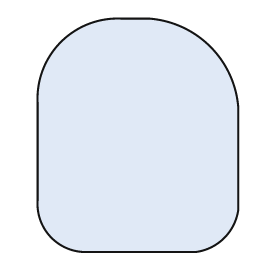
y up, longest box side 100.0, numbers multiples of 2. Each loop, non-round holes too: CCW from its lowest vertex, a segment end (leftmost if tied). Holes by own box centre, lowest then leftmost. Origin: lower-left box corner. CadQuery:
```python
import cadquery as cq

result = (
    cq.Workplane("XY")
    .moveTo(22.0, 0.0)
    .lineTo(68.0, 0.0)
    .threePointArc((80.0, 6.0), (86.0, 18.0))
    .lineTo(86.0, 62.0)
    .threePointArc((74.0, 88.0), (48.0, 100.0))
    .lineTo(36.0, 100.0)
    .threePointArc((10.0, 90.0), (0.0, 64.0))
    .lineTo(0.0, 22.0)
    .threePointArc((6.0, 6.0), (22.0, 0.0))
    .close()
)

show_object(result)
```